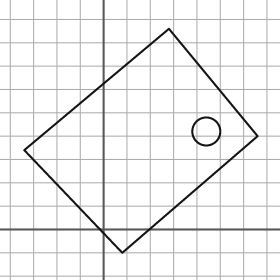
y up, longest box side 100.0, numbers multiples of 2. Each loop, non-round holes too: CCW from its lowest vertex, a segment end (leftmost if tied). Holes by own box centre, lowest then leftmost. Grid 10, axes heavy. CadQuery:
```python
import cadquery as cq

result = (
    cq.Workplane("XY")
    .moveTo(8.0, -10.0)
    .lineTo(66.0, 40.0)
    .lineTo(28.0, 86.0)
    .lineTo(-34.0, 34.0)
    .close()
    .moveTo(44.0, 42.0)
    .circle(6.0)
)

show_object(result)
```